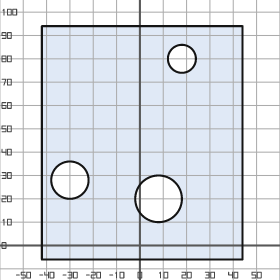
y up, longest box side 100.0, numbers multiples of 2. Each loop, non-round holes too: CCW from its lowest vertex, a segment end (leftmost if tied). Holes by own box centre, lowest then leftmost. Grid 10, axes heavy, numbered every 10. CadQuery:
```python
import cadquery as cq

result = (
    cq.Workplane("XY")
    .moveTo(-42.0, -6.0)
    .lineTo(44.0, -6.0)
    .lineTo(44.0, 94.0)
    .lineTo(-42.0, 94.0)
    .close()
    .moveTo(8.0, 20.0)
    .circle(10.0)
    .moveTo(-30.0, 28.0)
    .circle(8.0)
    .moveTo(18.0, 80.0)
    .circle(6.0)
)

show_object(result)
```